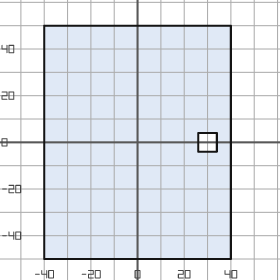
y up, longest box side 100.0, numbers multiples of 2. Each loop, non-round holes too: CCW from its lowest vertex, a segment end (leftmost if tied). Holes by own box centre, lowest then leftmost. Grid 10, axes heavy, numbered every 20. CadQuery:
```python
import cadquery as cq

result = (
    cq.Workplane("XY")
    .moveTo(-40.0, -50.0)
    .lineTo(40.0, -50.0)
    .lineTo(40.0, 50.0)
    .lineTo(-40.0, 50.0)
    .close()
    .moveTo(26.0, -4.0)
    .lineTo(34.0, -4.0)
    .lineTo(34.0, 4.0)
    .lineTo(26.0, 4.0)
    .close()
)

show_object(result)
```